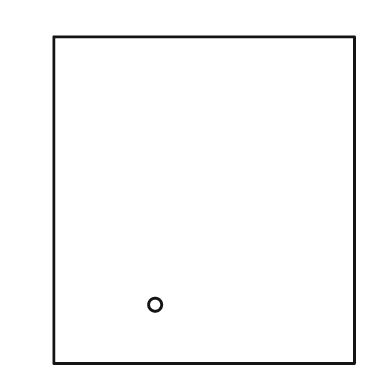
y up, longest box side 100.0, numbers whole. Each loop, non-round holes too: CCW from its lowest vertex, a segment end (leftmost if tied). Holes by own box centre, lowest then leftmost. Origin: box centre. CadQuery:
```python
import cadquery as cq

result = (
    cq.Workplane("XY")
    .moveTo(-46.0, -50.0)
    .lineTo(46.0, -50.0)
    .lineTo(46.0, 50.0)
    .lineTo(-46.0, 50.0)
    .close()
    .moveTo(-15.0, -32.0)
    .circle(2.0)
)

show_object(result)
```